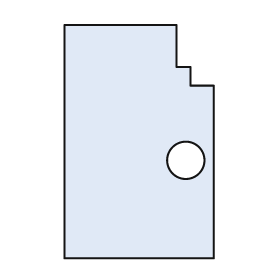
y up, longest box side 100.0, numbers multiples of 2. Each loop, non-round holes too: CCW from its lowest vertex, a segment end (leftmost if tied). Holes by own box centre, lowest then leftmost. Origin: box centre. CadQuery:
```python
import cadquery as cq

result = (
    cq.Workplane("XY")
    .moveTo(-32.0, -50.0)
    .lineTo(32.0, -50.0)
    .lineTo(32.0, 24.0)
    .lineTo(22.0, 24.0)
    .lineTo(22.0, 32.0)
    .lineTo(16.0, 32.0)
    .lineTo(16.0, 50.0)
    .lineTo(-32.0, 50.0)
    .close()
    .moveTo(20.0, -8.0)
    .circle(8.0)
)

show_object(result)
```